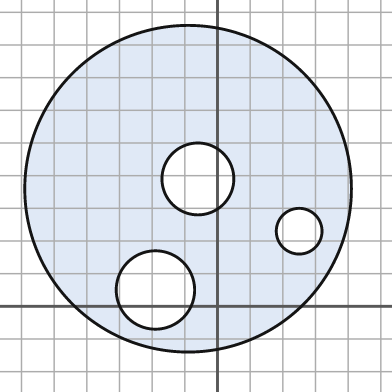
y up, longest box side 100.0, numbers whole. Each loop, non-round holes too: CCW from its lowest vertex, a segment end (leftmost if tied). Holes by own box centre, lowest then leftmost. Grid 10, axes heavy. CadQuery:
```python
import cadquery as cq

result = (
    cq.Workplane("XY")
    .moveTo(-9.0, 36.0)
    .circle(50.0)
    .moveTo(-19.0, 5.0)
    .circle(12.0)
    .moveTo(25.0, 23.0)
    .circle(7.0)
    .moveTo(-6.0, 39.0)
    .circle(11.0)
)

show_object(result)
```